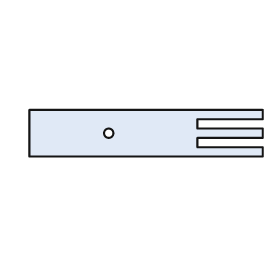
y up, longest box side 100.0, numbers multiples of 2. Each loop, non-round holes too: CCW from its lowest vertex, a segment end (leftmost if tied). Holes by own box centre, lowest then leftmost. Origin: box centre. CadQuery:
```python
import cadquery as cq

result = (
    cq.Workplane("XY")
    .moveTo(-50.0, -10.0)
    .lineTo(50.0, -10.0)
    .lineTo(50.0, -6.0)
    .lineTo(22.0, -6.0)
    .lineTo(22.0, -2.0)
    .lineTo(50.0, -2.0)
    .lineTo(50.0, 2.0)
    .lineTo(22.0, 2.0)
    .lineTo(22.0, 6.0)
    .lineTo(50.0, 6.0)
    .lineTo(50.0, 10.0)
    .lineTo(-50.0, 10.0)
    .close()
    .moveTo(-16.0, 0.0)
    .circle(2.0)
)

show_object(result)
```